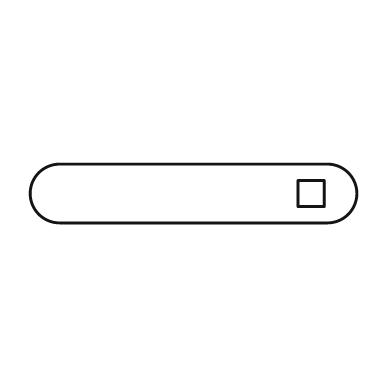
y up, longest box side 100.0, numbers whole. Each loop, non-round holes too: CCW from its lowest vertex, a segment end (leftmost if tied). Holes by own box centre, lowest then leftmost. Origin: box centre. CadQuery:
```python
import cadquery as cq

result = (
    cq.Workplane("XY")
    .moveTo(-41.0, -9.0)
    .lineTo(41.0, -9.0)
    .threePointArc((50.0, 0.0), (41.0, 9.0))
    .lineTo(-41.0, 9.0)
    .threePointArc((-50.0, 0.0), (-41.0, -9.0))
    .close()
    .moveTo(32.0, -4.0)
    .lineTo(40.0, -4.0)
    .lineTo(40.0, 4.0)
    .lineTo(32.0, 4.0)
    .close()
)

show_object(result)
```